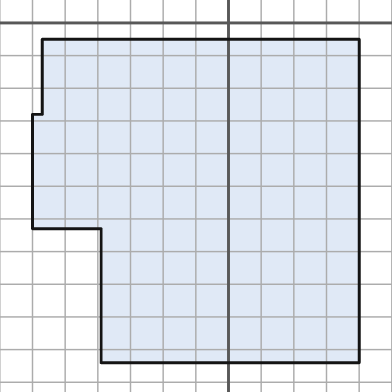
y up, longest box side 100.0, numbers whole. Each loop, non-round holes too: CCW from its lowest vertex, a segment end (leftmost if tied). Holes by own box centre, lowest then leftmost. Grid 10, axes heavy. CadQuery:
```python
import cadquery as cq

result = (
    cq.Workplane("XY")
    .moveTo(-39.0, -104.0)
    .lineTo(40.0, -104.0)
    .lineTo(40.0, -5.0)
    .lineTo(-57.0, -5.0)
    .lineTo(-57.0, -28.0)
    .lineTo(-60.0, -28.0)
    .lineTo(-60.0, -63.0)
    .lineTo(-39.0, -63.0)
    .close()
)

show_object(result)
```